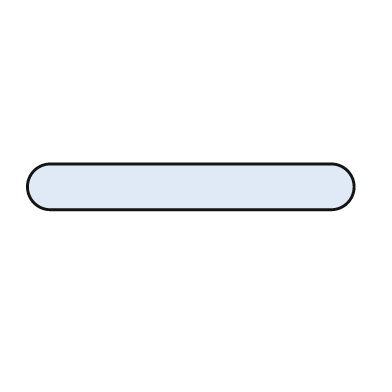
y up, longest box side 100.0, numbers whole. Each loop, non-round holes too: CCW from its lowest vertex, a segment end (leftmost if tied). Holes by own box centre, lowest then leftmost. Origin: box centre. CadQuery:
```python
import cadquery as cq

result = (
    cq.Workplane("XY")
    .moveTo(-43.0, -7.0)
    .lineTo(43.0, -7.0)
    .threePointArc((50.0, 0.0), (43.0, 7.0))
    .lineTo(-43.0, 7.0)
    .threePointArc((-50.0, 0.0), (-43.0, -7.0))
    .close()
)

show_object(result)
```